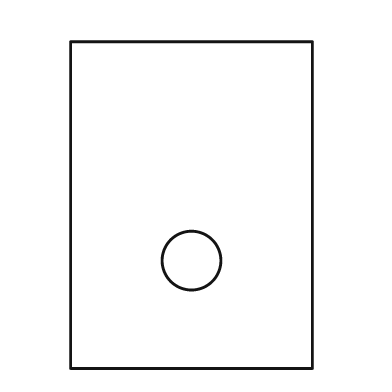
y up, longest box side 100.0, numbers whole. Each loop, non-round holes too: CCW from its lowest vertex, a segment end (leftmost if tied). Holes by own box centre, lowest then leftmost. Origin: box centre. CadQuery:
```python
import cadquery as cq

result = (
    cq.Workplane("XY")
    .moveTo(-37.0, -50.0)
    .lineTo(37.0, -50.0)
    .lineTo(37.0, 50.0)
    .lineTo(-37.0, 50.0)
    .close()
    .moveTo(0.0, -17.0)
    .circle(9.0)
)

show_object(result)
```